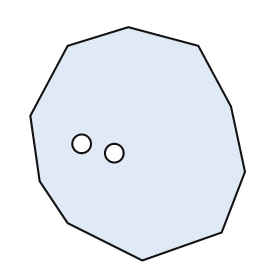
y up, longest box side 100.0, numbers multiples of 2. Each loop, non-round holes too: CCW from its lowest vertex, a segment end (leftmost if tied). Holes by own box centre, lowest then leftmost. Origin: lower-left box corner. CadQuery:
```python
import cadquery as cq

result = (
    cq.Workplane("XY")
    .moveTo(48.0, 0.0)
    .lineTo(82.0, 12.0)
    .lineTo(92.0, 38.0)
    .lineTo(86.0, 66.0)
    .lineTo(72.0, 92.0)
    .lineTo(42.0, 100.0)
    .lineTo(16.0, 92.0)
    .lineTo(0.0, 62.0)
    .lineTo(4.0, 34.0)
    .lineTo(16.0, 16.0)
    .close()
    .moveTo(36.0, 46.0)
    .circle(4.0)
    .moveTo(22.0, 50.0)
    .circle(4.0)
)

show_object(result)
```